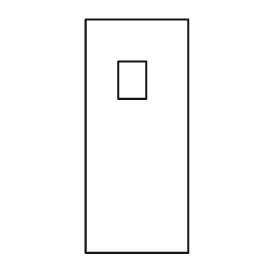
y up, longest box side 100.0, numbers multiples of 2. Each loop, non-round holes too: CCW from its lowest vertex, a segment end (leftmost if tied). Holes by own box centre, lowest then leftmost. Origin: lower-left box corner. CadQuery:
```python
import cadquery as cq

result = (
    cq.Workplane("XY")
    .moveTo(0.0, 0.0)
    .lineTo(44.0, 0.0)
    .lineTo(44.0, 100.0)
    .lineTo(0.0, 100.0)
    .close()
    .moveTo(14.0, 66.0)
    .lineTo(26.0, 66.0)
    .lineTo(26.0, 82.0)
    .lineTo(14.0, 82.0)
    .close()
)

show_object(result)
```